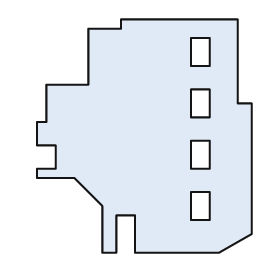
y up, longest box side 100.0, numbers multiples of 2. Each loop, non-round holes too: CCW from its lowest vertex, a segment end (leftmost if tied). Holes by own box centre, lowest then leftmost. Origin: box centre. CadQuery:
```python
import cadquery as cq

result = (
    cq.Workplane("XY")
    .moveTo(-18.0, -50.0)
    .lineTo(-12.0, -50.0)
    .lineTo(-12.0, -34.0)
    .lineTo(-4.0, -34.0)
    .lineTo(-4.0, -50.0)
    .lineTo(32.0, -50.0)
    .lineTo(46.0, -42.0)
    .lineTo(46.0, 14.0)
    .lineTo(40.0, 14.0)
    .lineTo(40.0, 50.0)
    .lineTo(-10.0, 50.0)
    .lineTo(-10.0, 46.0)
    .lineTo(-24.0, 46.0)
    .lineTo(-24.0, 22.0)
    .lineTo(-42.0, 22.0)
    .lineTo(-42.0, 6.0)
    .lineTo(-46.0, 6.0)
    .lineTo(-46.0, -4.0)
    .lineTo(-38.0, -4.0)
    .lineTo(-38.0, -14.0)
    .lineTo(-46.0, -14.0)
    .lineTo(-46.0, -18.0)
    .lineTo(-30.0, -18.0)
    .lineTo(-18.0, -30.0)
    .close()
    .moveTo(20.0, -36.0)
    .lineTo(28.0, -36.0)
    .lineTo(28.0, -24.0)
    .lineTo(20.0, -24.0)
    .close()
    .moveTo(20.0, -14.0)
    .lineTo(28.0, -14.0)
    .lineTo(28.0, -2.0)
    .lineTo(20.0, -2.0)
    .close()
    .moveTo(20.0, 8.0)
    .lineTo(28.0, 8.0)
    .lineTo(28.0, 20.0)
    .lineTo(20.0, 20.0)
    .close()
    .moveTo(20.0, 30.0)
    .lineTo(28.0, 30.0)
    .lineTo(28.0, 42.0)
    .lineTo(20.0, 42.0)
    .close()
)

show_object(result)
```